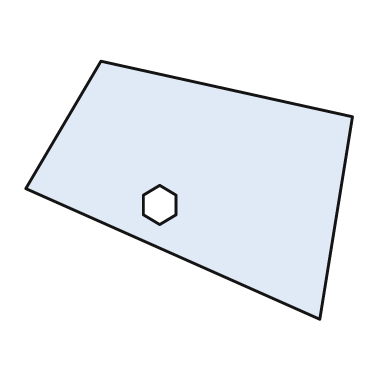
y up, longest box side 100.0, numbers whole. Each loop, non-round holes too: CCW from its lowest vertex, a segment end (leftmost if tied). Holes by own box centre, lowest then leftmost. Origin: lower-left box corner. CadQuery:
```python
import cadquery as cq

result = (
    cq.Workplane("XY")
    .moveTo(90.0, 0.0)
    .lineTo(100.0, 62.0)
    .lineTo(23.0, 79.0)
    .lineTo(0.0, 40.0)
    .close()
    .moveTo(41.0, 29.0)
    .lineTo(46.0, 32.0)
    .lineTo(46.0, 38.0)
    .lineTo(41.0, 41.0)
    .lineTo(36.0, 38.0)
    .lineTo(36.0, 32.0)
    .close()
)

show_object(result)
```